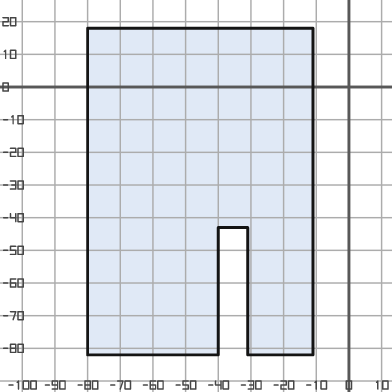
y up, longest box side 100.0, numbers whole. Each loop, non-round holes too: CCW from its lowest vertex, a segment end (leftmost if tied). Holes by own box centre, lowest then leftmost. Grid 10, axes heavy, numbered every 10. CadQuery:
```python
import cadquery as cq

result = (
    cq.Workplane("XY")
    .moveTo(-80.0, -82.0)
    .lineTo(-40.0, -82.0)
    .lineTo(-40.0, -43.0)
    .lineTo(-31.0, -43.0)
    .lineTo(-31.0, -82.0)
    .lineTo(-11.0, -82.0)
    .lineTo(-11.0, 18.0)
    .lineTo(-80.0, 18.0)
    .close()
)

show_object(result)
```